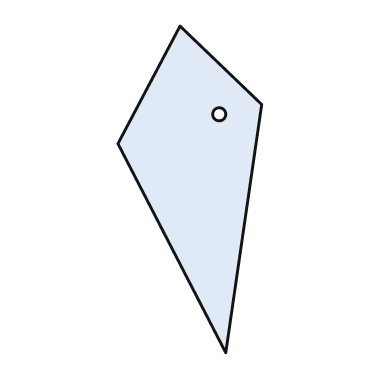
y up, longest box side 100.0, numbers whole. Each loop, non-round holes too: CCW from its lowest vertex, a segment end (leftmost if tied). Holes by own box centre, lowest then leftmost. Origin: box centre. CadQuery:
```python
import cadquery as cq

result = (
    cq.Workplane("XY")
    .moveTo(11.0, -50.0)
    .lineTo(22.0, 26.0)
    .lineTo(-3.0, 50.0)
    .lineTo(-22.0, 14.0)
    .close()
    .moveTo(9.0, 23.0)
    .circle(2.0)
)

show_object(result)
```